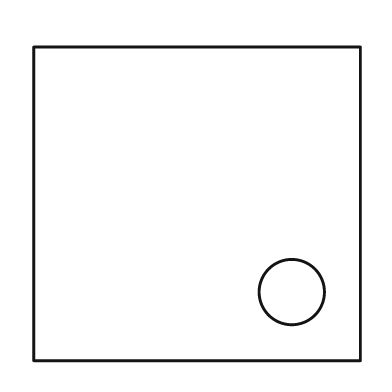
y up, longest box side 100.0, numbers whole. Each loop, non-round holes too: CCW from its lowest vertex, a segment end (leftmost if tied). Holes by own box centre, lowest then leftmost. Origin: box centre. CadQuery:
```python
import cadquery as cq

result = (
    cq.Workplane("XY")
    .moveTo(-50.0, -48.0)
    .lineTo(50.0, -48.0)
    .lineTo(50.0, 48.0)
    .lineTo(-50.0, 48.0)
    .close()
    .moveTo(29.0, -27.0)
    .circle(10.0)
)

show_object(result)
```